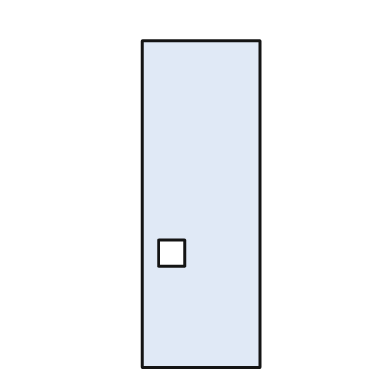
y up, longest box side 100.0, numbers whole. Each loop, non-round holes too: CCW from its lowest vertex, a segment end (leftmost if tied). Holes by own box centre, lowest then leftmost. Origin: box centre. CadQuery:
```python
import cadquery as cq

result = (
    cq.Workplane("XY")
    .moveTo(-18.0, -50.0)
    .lineTo(18.0, -50.0)
    .lineTo(18.0, 50.0)
    .lineTo(-18.0, 50.0)
    .close()
    .moveTo(-13.0, -19.0)
    .lineTo(-5.0, -19.0)
    .lineTo(-5.0, -11.0)
    .lineTo(-13.0, -11.0)
    .close()
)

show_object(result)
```